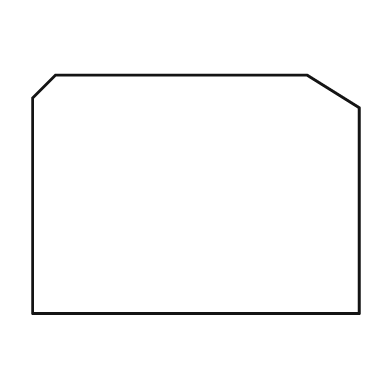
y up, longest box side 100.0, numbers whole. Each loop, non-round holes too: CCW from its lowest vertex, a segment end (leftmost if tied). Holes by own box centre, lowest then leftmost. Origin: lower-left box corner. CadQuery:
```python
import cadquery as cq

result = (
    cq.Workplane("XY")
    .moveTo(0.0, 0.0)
    .lineTo(100.0, 0.0)
    .lineTo(100.0, 63.0)
    .lineTo(84.0, 73.0)
    .lineTo(7.0, 73.0)
    .lineTo(0.0, 66.0)
    .close()
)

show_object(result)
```